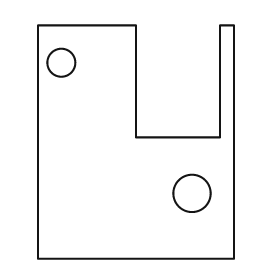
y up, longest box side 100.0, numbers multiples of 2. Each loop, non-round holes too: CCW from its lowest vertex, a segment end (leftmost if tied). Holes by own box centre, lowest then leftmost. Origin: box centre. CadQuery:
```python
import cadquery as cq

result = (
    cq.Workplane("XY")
    .moveTo(-42.0, -50.0)
    .lineTo(42.0, -50.0)
    .lineTo(42.0, 50.0)
    .lineTo(36.0, 50.0)
    .lineTo(36.0, 2.0)
    .lineTo(0.0, 2.0)
    .lineTo(0.0, 50.0)
    .lineTo(-42.0, 50.0)
    .close()
    .moveTo(24.0, -22.0)
    .circle(8.0)
    .moveTo(-32.0, 34.0)
    .circle(6.0)
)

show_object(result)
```